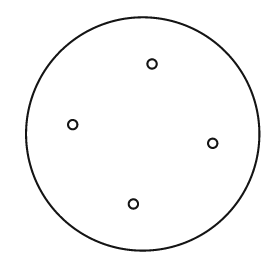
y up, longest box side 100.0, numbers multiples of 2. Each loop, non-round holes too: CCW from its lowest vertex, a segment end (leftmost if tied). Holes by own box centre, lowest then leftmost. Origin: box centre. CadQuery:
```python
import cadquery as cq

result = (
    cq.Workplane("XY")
    .moveTo(0.0, 0.0)
    .circle(50.0)
    .moveTo(-4.0, -30.0)
    .circle(2.0)
    .moveTo(30.0, -4.0)
    .circle(2.0)
    .moveTo(-30.0, 4.0)
    .circle(2.0)
    .moveTo(4.0, 30.0)
    .circle(2.0)
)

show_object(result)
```